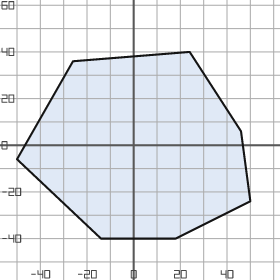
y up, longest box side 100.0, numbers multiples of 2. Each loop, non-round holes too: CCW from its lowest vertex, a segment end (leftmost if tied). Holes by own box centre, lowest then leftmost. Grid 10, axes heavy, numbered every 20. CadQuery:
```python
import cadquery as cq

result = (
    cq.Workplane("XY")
    .moveTo(-14.0, -40.0)
    .lineTo(18.0, -40.0)
    .lineTo(50.0, -24.0)
    .lineTo(46.0, 6.0)
    .lineTo(24.0, 40.0)
    .lineTo(-26.0, 36.0)
    .lineTo(-50.0, -6.0)
    .close()
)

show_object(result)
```